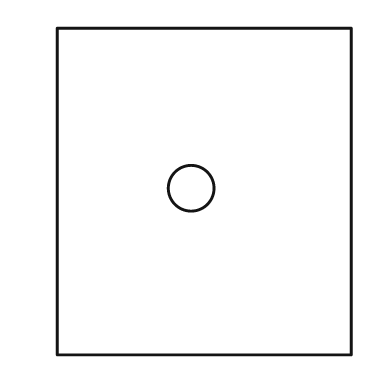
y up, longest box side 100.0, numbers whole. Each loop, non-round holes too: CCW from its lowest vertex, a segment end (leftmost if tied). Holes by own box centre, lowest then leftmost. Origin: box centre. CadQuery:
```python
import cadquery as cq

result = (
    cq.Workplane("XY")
    .moveTo(-45.0, -50.0)
    .lineTo(45.0, -50.0)
    .lineTo(45.0, 50.0)
    .lineTo(-45.0, 50.0)
    .close()
    .moveTo(-4.0, 1.0)
    .circle(7.0)
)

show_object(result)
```